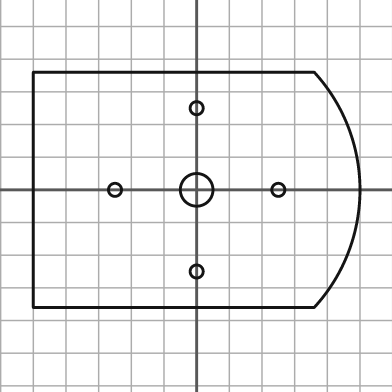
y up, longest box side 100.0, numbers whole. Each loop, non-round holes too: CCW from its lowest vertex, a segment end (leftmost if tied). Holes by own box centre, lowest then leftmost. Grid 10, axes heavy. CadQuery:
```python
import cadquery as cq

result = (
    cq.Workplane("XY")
    .moveTo(-50.0, -36.0)
    .lineTo(36.0, -36.0)
    .threePointArc((50.0, 0.0), (36.0, 36.0))
    .lineTo(-50.0, 36.0)
    .close()
    .moveTo(0.0, -25.0)
    .circle(2.0)
    .moveTo(-25.0, 0.0)
    .circle(2.0)
    .moveTo(0.0, 0.0)
    .circle(5.0)
    .moveTo(25.0, 0.0)
    .circle(2.0)
    .moveTo(0.0, 25.0)
    .circle(2.0)
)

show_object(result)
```